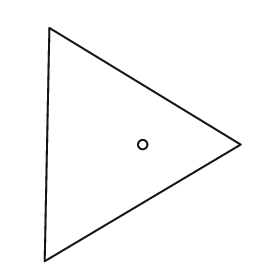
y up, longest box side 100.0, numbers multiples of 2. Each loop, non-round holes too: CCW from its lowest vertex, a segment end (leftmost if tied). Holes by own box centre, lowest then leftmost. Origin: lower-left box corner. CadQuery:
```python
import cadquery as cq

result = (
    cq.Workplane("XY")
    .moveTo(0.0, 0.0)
    .lineTo(84.0, 50.0)
    .lineTo(2.0, 100.0)
    .close()
    .moveTo(42.0, 50.0)
    .circle(2.0)
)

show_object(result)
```